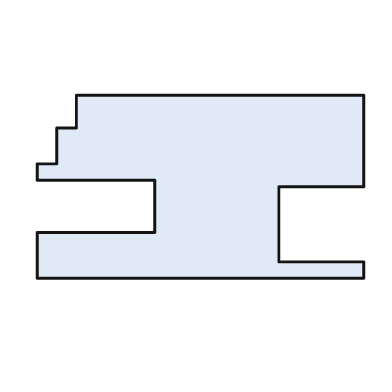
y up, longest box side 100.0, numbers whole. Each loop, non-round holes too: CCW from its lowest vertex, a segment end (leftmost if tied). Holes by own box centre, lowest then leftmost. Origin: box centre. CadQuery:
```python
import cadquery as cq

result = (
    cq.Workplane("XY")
    .moveTo(-50.0, -28.0)
    .lineTo(50.0, -28.0)
    .lineTo(50.0, -23.0)
    .lineTo(24.0, -23.0)
    .lineTo(24.0, 0.0)
    .lineTo(50.0, 0.0)
    .lineTo(50.0, 28.0)
    .lineTo(-38.0, 28.0)
    .lineTo(-38.0, 18.0)
    .lineTo(-44.0, 18.0)
    .lineTo(-44.0, 7.0)
    .lineTo(-50.0, 7.0)
    .lineTo(-50.0, 2.0)
    .lineTo(-14.0, 2.0)
    .lineTo(-14.0, -14.0)
    .lineTo(-50.0, -14.0)
    .close()
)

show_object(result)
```